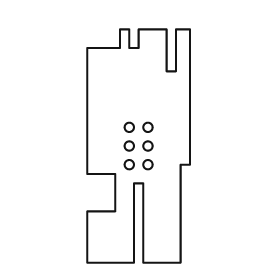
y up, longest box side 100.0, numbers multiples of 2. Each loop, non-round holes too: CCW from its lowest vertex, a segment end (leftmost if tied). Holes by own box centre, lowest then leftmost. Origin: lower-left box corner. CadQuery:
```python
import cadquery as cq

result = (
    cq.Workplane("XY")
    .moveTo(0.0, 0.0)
    .lineTo(20.0, 0.0)
    .lineTo(20.0, 34.0)
    .lineTo(24.0, 34.0)
    .lineTo(24.0, 0.0)
    .lineTo(40.0, 0.0)
    .lineTo(40.0, 42.0)
    .lineTo(44.0, 42.0)
    .lineTo(44.0, 100.0)
    .lineTo(38.0, 100.0)
    .lineTo(38.0, 82.0)
    .lineTo(34.0, 82.0)
    .lineTo(34.0, 100.0)
    .lineTo(22.0, 100.0)
    .lineTo(22.0, 92.0)
    .lineTo(18.0, 92.0)
    .lineTo(18.0, 100.0)
    .lineTo(14.0, 100.0)
    .lineTo(14.0, 92.0)
    .lineTo(0.0, 92.0)
    .lineTo(0.0, 38.0)
    .lineTo(12.0, 38.0)
    .lineTo(12.0, 22.0)
    .lineTo(0.0, 22.0)
    .close()
    .moveTo(18.0, 42.0)
    .circle(2.0)
    .moveTo(26.0, 42.0)
    .circle(2.0)
    .moveTo(18.0, 50.0)
    .circle(2.0)
    .moveTo(26.0, 50.0)
    .circle(2.0)
    .moveTo(18.0, 58.0)
    .circle(2.0)
    .moveTo(26.0, 58.0)
    .circle(2.0)
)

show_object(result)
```